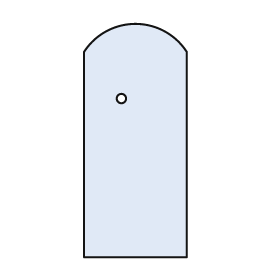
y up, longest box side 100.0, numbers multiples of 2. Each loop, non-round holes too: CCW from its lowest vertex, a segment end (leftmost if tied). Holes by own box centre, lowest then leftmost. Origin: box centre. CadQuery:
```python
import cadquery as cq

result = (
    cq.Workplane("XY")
    .moveTo(-22.0, -50.0)
    .lineTo(22.0, -50.0)
    .lineTo(22.0, 38.0)
    .threePointArc((0.0, 50.0), (-22.0, 38.0))
    .close()
    .moveTo(-6.0, 18.0)
    .circle(2.0)
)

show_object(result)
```